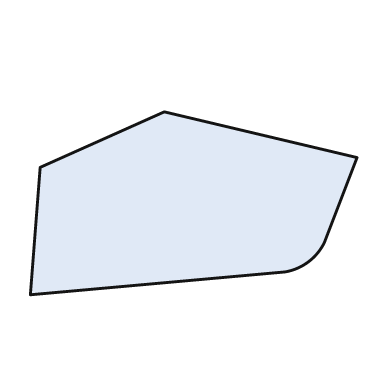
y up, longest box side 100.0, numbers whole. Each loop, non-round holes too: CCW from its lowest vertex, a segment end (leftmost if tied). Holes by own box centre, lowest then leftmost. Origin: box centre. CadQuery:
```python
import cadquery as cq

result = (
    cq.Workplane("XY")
    .moveTo(-50.0, -28.0)
    .lineTo(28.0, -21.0)
    .threePointArc((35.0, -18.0), (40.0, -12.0))
    .lineTo(50.0, 14.0)
    .lineTo(-9.0, 28.0)
    .lineTo(-47.0, 11.0)
    .close()
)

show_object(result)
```